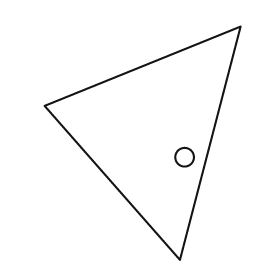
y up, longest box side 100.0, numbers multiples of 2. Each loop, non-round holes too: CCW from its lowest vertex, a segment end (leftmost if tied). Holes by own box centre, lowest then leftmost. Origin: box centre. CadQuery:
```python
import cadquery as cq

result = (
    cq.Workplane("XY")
    .moveTo(16.0, -50.0)
    .lineTo(42.0, 50.0)
    .lineTo(-42.0, 16.0)
    .close()
    .moveTo(18.0, -6.0)
    .circle(4.0)
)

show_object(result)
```